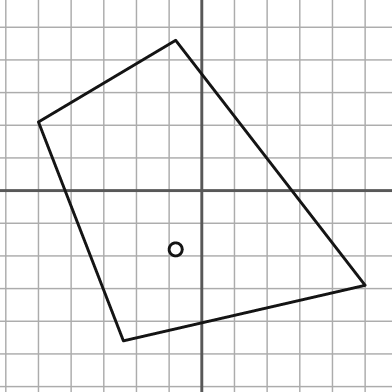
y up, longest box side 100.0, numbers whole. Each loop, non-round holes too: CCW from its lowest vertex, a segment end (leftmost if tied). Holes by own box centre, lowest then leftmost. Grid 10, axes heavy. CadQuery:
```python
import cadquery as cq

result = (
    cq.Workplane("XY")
    .moveTo(-24.0, -46.0)
    .lineTo(50.0, -29.0)
    .lineTo(-8.0, 46.0)
    .lineTo(-50.0, 21.0)
    .close()
    .moveTo(-8.0, -18.0)
    .circle(2.0)
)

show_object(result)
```